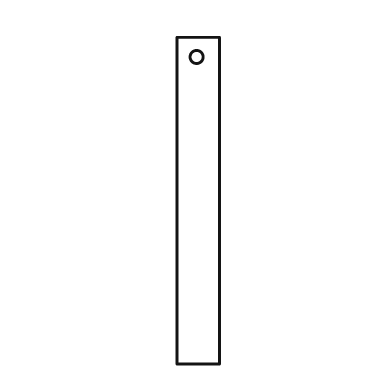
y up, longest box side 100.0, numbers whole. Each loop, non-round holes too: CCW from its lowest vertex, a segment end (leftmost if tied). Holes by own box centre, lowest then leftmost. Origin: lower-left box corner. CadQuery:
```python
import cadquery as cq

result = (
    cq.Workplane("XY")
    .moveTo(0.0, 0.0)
    .lineTo(13.0, 0.0)
    .lineTo(13.0, 100.0)
    .lineTo(0.0, 100.0)
    .close()
    .moveTo(6.0, 94.0)
    .circle(2.0)
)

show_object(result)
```